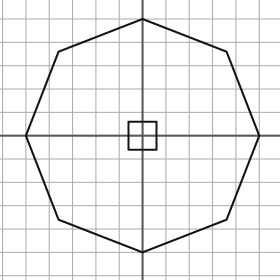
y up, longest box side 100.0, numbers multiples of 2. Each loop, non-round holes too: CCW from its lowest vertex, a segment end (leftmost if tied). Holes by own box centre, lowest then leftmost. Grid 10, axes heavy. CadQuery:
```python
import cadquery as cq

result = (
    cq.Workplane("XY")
    .moveTo(0.0, -50.0)
    .lineTo(36.0, -36.0)
    .lineTo(50.0, 0.0)
    .lineTo(36.0, 36.0)
    .lineTo(0.0, 50.0)
    .lineTo(-36.0, 36.0)
    .lineTo(-50.0, 0.0)
    .lineTo(-36.0, -36.0)
    .close()
    .moveTo(-6.0, -6.0)
    .lineTo(6.0, -6.0)
    .lineTo(6.0, 6.0)
    .lineTo(-6.0, 6.0)
    .close()
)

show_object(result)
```